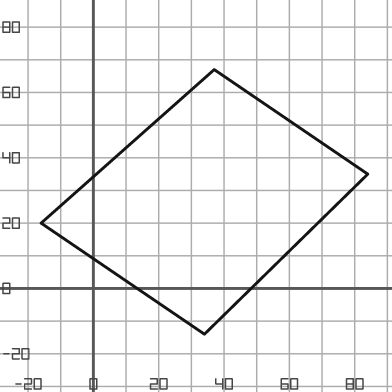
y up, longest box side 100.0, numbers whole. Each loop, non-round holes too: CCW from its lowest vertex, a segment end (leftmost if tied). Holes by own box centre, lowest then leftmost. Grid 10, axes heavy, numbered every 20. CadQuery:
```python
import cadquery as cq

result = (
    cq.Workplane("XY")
    .moveTo(34.0, -14.0)
    .lineTo(84.0, 35.0)
    .lineTo(37.0, 67.0)
    .lineTo(-16.0, 20.0)
    .close()
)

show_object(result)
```